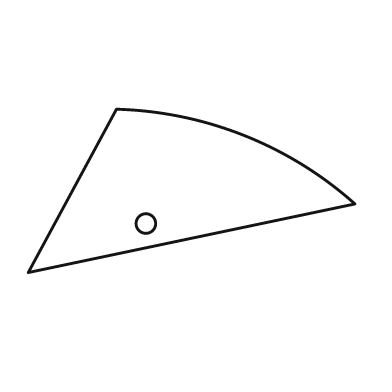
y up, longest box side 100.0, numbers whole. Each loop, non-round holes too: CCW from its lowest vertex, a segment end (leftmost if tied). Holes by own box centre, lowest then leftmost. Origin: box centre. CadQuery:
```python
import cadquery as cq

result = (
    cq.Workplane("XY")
    .moveTo(-50.0, -25.0)
    .lineTo(50.0, -4.0)
    .threePointArc((16.0, 17.0), (-23.0, 25.0))
    .close()
    .moveTo(-14.0, -10.0)
    .circle(3.0)
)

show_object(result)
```